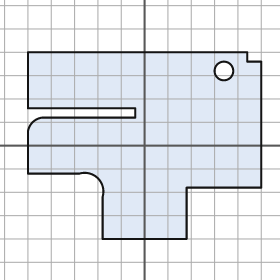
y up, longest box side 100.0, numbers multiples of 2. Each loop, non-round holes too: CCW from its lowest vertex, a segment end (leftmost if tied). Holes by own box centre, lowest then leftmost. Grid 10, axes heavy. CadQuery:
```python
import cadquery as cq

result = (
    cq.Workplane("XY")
    .moveTo(-18.0, -40.0)
    .lineTo(18.0, -40.0)
    .lineTo(18.0, -18.0)
    .lineTo(50.0, -18.0)
    .lineTo(50.0, 36.0)
    .lineTo(44.0, 36.0)
    .lineTo(44.0, 40.0)
    .lineTo(-50.0, 40.0)
    .lineTo(-50.0, 16.0)
    .lineTo(-4.0, 16.0)
    .lineTo(-4.0, 12.0)
    .lineTo(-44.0, 12.0)
    .threePointArc((-48.0, 10.0), (-50.0, 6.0))
    .lineTo(-50.0, -12.0)
    .lineTo(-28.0, -12.0)
    .threePointArc((-20.0, -14.0), (-18.0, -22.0))
    .close()
    .moveTo(34.0, 32.0)
    .circle(4.0)
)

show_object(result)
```